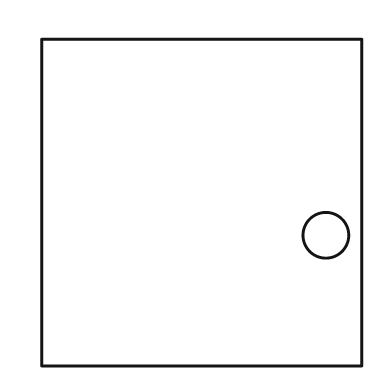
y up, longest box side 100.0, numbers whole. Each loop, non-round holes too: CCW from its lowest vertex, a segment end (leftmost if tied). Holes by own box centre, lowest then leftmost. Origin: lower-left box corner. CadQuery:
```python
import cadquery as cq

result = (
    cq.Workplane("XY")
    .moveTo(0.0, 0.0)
    .lineTo(98.0, 0.0)
    .lineTo(98.0, 100.0)
    .lineTo(0.0, 100.0)
    .close()
    .moveTo(87.0, 40.0)
    .circle(7.0)
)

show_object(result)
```